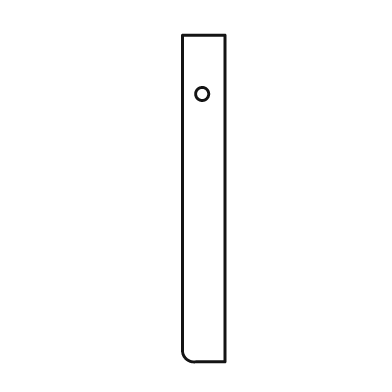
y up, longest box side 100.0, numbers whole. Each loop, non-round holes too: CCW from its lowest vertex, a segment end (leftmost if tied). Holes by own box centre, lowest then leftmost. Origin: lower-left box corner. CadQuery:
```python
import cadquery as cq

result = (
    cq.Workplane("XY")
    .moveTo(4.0, 0.0)
    .lineTo(13.0, 0.0)
    .lineTo(13.0, 100.0)
    .lineTo(0.0, 100.0)
    .lineTo(0.0, 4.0)
    .threePointArc((1.0, 1.0), (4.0, 0.0))
    .close()
    .moveTo(6.0, 82.0)
    .circle(2.0)
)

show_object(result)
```